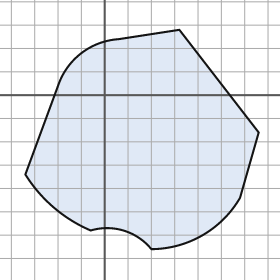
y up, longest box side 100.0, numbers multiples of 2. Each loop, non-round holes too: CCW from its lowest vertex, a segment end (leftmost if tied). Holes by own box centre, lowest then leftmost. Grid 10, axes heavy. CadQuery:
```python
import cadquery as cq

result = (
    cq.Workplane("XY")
    .moveTo(20.0, -66.0)
    .threePointArc((42.0, -60.0), (58.0, -44.0))
    .lineTo(66.0, -16.0)
    .lineTo(32.0, 28.0)
    .lineTo(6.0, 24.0)
    .threePointArc((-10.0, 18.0), (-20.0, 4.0))
    .lineTo(-34.0, -34.0)
    .threePointArc((-22.0, -48.0), (-6.0, -58.0))
    .threePointArc((8.0, -58.0), (20.0, -66.0))
    .close()
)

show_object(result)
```